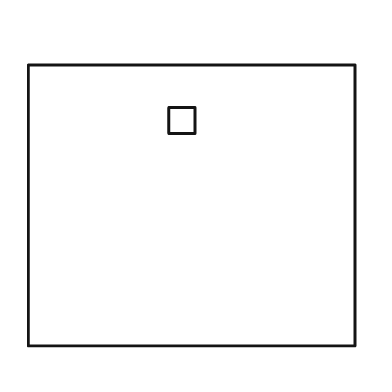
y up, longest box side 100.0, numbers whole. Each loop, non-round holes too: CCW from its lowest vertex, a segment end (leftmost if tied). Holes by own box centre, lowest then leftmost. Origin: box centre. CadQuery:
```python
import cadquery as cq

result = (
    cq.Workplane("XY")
    .moveTo(-50.0, -43.0)
    .lineTo(50.0, -43.0)
    .lineTo(50.0, 43.0)
    .lineTo(-50.0, 43.0)
    .close()
    .moveTo(-7.0, 22.0)
    .lineTo(1.0, 22.0)
    .lineTo(1.0, 30.0)
    .lineTo(-7.0, 30.0)
    .close()
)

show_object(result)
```